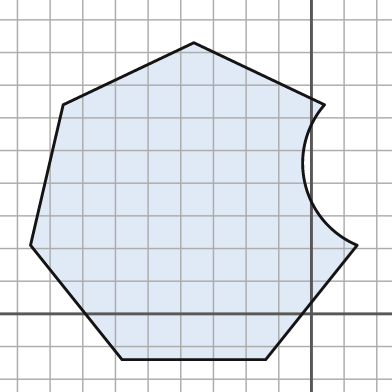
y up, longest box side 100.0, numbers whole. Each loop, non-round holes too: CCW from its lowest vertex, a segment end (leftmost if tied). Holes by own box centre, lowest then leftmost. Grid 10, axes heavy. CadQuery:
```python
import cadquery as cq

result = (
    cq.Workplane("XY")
    .moveTo(-58.0, -14.0)
    .lineTo(-14.0, -14.0)
    .lineTo(14.0, 21.0)
    .threePointArc((-2.0, 40.0), (4.0, 64.0))
    .lineTo(-36.0, 83.0)
    .lineTo(-76.0, 64.0)
    .lineTo(-86.0, 21.0)
    .close()
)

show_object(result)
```